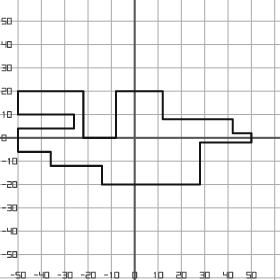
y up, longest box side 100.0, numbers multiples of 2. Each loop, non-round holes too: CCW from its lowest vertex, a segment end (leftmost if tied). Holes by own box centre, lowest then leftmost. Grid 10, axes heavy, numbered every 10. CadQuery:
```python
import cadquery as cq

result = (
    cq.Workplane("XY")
    .moveTo(-14.0, -20.0)
    .lineTo(28.0, -20.0)
    .lineTo(28.0, -2.0)
    .lineTo(50.0, -2.0)
    .lineTo(50.0, 2.0)
    .lineTo(42.0, 2.0)
    .lineTo(42.0, 8.0)
    .lineTo(12.0, 8.0)
    .lineTo(12.0, 20.0)
    .lineTo(-8.0, 20.0)
    .lineTo(-8.0, 0.0)
    .lineTo(-22.0, 0.0)
    .lineTo(-22.0, 20.0)
    .lineTo(-50.0, 20.0)
    .lineTo(-50.0, 10.0)
    .lineTo(-26.0, 10.0)
    .lineTo(-26.0, 4.0)
    .lineTo(-50.0, 4.0)
    .lineTo(-50.0, -6.0)
    .lineTo(-36.0, -6.0)
    .lineTo(-36.0, -12.0)
    .lineTo(-14.0, -12.0)
    .close()
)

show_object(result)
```